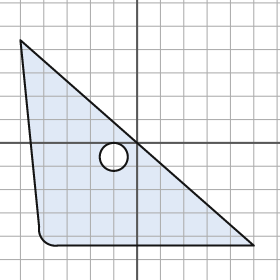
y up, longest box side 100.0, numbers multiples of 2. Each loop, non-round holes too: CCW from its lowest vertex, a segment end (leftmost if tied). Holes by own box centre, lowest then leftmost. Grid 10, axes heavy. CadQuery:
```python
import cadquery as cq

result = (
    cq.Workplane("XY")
    .moveTo(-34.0, -44.0)
    .lineTo(50.0, -44.0)
    .lineTo(-50.0, 44.0)
    .lineTo(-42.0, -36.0)
    .threePointArc((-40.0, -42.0), (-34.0, -44.0))
    .close()
    .moveTo(-10.0, -6.0)
    .circle(6.0)
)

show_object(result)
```